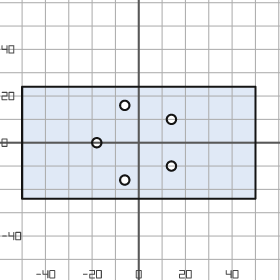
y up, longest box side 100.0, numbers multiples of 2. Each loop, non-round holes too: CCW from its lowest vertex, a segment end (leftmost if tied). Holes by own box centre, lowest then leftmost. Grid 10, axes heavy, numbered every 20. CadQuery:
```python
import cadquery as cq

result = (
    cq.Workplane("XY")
    .moveTo(-50.0, -24.0)
    .lineTo(50.0, -24.0)
    .lineTo(50.0, 24.0)
    .lineTo(-50.0, 24.0)
    .close()
    .moveTo(-6.0, -16.0)
    .circle(2.0)
    .moveTo(14.0, -10.0)
    .circle(2.0)
    .moveTo(-18.0, 0.0)
    .circle(2.0)
    .moveTo(14.0, 10.0)
    .circle(2.0)
    .moveTo(-6.0, 16.0)
    .circle(2.0)
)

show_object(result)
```